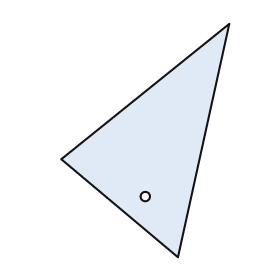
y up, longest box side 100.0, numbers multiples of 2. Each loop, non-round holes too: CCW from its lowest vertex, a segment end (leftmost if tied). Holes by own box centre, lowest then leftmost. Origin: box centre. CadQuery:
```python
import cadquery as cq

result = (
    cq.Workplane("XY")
    .moveTo(14.0, -50.0)
    .lineTo(36.0, 50.0)
    .lineTo(-36.0, -8.0)
    .close()
    .moveTo(0.0, -24.0)
    .circle(2.0)
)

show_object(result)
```